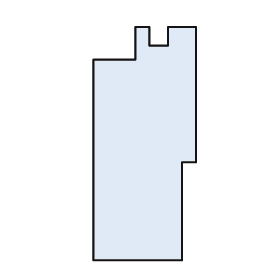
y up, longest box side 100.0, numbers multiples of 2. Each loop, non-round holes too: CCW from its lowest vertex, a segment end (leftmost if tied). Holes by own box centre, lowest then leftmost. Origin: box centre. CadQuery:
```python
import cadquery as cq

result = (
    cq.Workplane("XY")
    .moveTo(-22.0, -50.0)
    .lineTo(16.0, -50.0)
    .lineTo(16.0, -8.0)
    .lineTo(22.0, -8.0)
    .lineTo(22.0, 50.0)
    .lineTo(10.0, 50.0)
    .lineTo(10.0, 42.0)
    .lineTo(2.0, 42.0)
    .lineTo(2.0, 50.0)
    .lineTo(-4.0, 50.0)
    .lineTo(-4.0, 36.0)
    .lineTo(-22.0, 36.0)
    .close()
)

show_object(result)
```